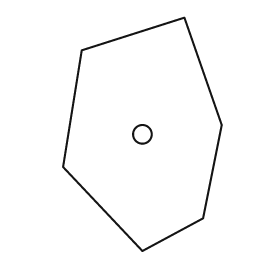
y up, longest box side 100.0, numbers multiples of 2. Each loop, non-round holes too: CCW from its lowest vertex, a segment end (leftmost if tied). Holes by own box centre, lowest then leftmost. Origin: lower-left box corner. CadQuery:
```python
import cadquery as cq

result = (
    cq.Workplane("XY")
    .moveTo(34.0, 0.0)
    .lineTo(60.0, 14.0)
    .lineTo(68.0, 54.0)
    .lineTo(52.0, 100.0)
    .lineTo(8.0, 86.0)
    .lineTo(0.0, 36.0)
    .close()
    .moveTo(34.0, 50.0)
    .circle(4.0)
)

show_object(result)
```